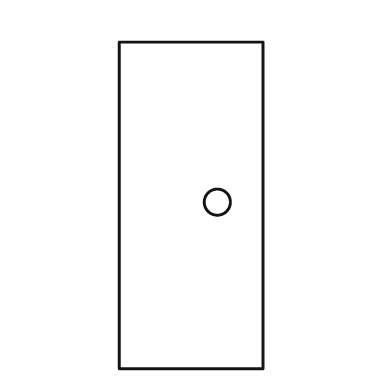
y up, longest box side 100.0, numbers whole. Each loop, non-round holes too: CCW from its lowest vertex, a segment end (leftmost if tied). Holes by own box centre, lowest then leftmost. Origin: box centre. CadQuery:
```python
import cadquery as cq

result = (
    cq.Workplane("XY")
    .moveTo(-22.0, -50.0)
    .lineTo(22.0, -50.0)
    .lineTo(22.0, 50.0)
    .lineTo(-22.0, 50.0)
    .close()
    .moveTo(8.0, 1.0)
    .circle(4.0)
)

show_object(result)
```